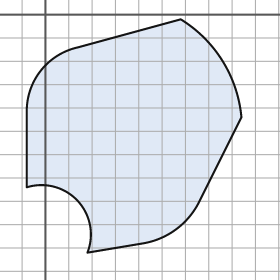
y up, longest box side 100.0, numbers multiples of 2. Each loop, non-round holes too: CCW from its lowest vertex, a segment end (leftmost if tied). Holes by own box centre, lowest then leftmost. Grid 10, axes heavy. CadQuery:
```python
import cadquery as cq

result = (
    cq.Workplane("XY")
    .moveTo(18.0, -102.0)
    .lineTo(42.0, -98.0)
    .threePointArc((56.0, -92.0), (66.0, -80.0))
    .lineTo(84.0, -44.0)
    .threePointArc((76.0, -20.0), (58.0, -2.0))
    .lineTo(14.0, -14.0)
    .threePointArc((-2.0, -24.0), (-8.0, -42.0))
    .lineTo(-8.0, -74.0)
    .threePointArc((14.0, -80.0), (18.0, -102.0))
    .close()
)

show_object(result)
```